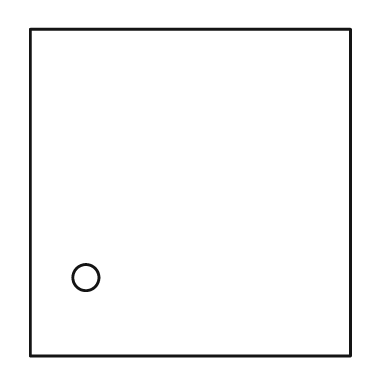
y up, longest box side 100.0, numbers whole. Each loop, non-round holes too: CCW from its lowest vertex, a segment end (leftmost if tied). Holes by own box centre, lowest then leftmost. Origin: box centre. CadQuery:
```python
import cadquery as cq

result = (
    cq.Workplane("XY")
    .moveTo(-49.0, -50.0)
    .lineTo(49.0, -50.0)
    .lineTo(49.0, 50.0)
    .lineTo(-49.0, 50.0)
    .close()
    .moveTo(-32.0, -26.0)
    .circle(4.0)
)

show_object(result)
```